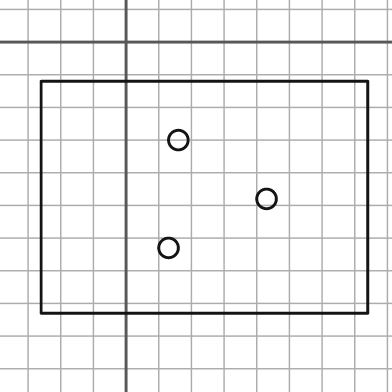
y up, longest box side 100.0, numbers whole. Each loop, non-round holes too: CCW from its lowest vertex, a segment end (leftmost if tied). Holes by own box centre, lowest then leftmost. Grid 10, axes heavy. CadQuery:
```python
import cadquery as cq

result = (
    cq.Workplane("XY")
    .moveTo(-26.0, -83.0)
    .lineTo(74.0, -83.0)
    .lineTo(74.0, -12.0)
    .lineTo(-26.0, -12.0)
    .close()
    .moveTo(13.0, -63.0)
    .circle(3.0)
    .moveTo(43.0, -48.0)
    .circle(3.0)
    .moveTo(16.0, -30.0)
    .circle(3.0)
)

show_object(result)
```